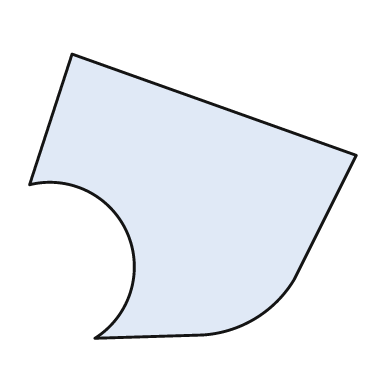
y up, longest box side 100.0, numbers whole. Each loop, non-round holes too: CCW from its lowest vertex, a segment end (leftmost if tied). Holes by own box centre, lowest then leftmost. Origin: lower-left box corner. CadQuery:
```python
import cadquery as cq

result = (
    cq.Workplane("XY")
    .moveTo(20.0, 0.0)
    .lineTo(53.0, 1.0)
    .threePointArc((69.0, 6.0), (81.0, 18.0))
    .lineTo(100.0, 56.0)
    .lineTo(13.0, 87.0)
    .lineTo(0.0, 47.0)
    .threePointArc((30.0, 32.0), (20.0, 0.0))
    .close()
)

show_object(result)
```